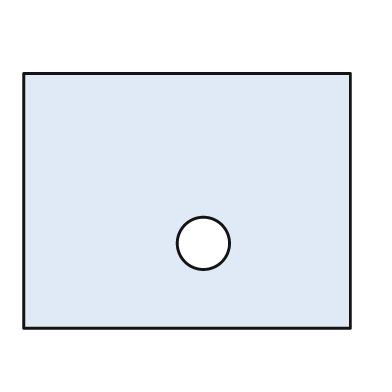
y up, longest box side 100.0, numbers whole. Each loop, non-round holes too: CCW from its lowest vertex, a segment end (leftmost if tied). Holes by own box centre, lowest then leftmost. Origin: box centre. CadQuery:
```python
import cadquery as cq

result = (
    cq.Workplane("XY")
    .moveTo(-50.0, -39.0)
    .lineTo(50.0, -39.0)
    .lineTo(50.0, 39.0)
    .lineTo(-50.0, 39.0)
    .close()
    .moveTo(5.0, -13.0)
    .circle(8.0)
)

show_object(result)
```